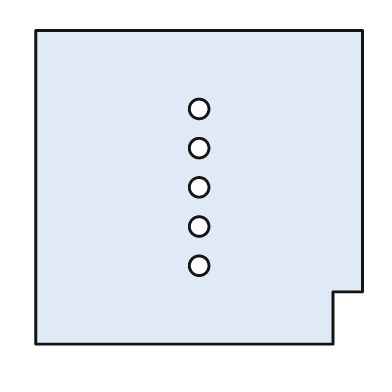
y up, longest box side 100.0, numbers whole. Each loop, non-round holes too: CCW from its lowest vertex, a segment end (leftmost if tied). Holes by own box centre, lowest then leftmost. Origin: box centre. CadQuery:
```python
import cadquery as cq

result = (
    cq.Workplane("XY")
    .moveTo(-50.0, -48.0)
    .lineTo(41.0, -48.0)
    .lineTo(41.0, -32.0)
    .lineTo(50.0, -32.0)
    .lineTo(50.0, 48.0)
    .lineTo(-50.0, 48.0)
    .close()
    .moveTo(0.0, -24.0)
    .circle(3.0)
    .moveTo(0.0, -12.0)
    .circle(3.0)
    .moveTo(0.0, 0.0)
    .circle(3.0)
    .moveTo(0.0, 12.0)
    .circle(3.0)
    .moveTo(0.0, 24.0)
    .circle(3.0)
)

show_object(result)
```